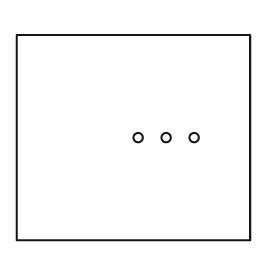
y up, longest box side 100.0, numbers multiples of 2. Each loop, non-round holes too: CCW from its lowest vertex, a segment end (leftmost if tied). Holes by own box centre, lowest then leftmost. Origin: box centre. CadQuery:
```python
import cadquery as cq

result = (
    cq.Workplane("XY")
    .moveTo(-50.0, -44.0)
    .lineTo(50.0, -44.0)
    .lineTo(50.0, 44.0)
    .lineTo(-50.0, 44.0)
    .close()
    .moveTo(2.0, 0.0)
    .circle(2.0)
    .moveTo(14.0, 0.0)
    .circle(2.0)
    .moveTo(26.0, 0.0)
    .circle(2.0)
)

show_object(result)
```